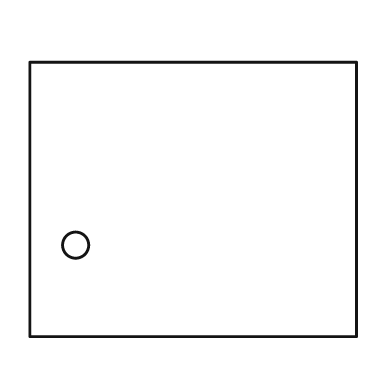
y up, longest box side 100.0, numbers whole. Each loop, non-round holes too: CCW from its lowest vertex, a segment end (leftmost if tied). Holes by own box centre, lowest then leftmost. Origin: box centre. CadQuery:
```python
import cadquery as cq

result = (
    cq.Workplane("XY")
    .moveTo(-50.0, -42.0)
    .lineTo(50.0, -42.0)
    .lineTo(50.0, 42.0)
    .lineTo(-50.0, 42.0)
    .close()
    .moveTo(-36.0, -14.0)
    .circle(4.0)
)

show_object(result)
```